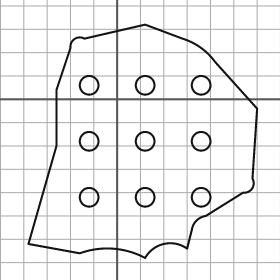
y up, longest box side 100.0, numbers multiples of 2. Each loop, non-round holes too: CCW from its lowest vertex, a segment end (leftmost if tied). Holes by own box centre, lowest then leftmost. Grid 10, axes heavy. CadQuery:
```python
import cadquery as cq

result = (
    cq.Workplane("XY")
    .moveTo(12.0, -68.0)
    .threePointArc((20.0, -62.0), (30.0, -64.0))
    .lineTo(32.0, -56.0)
    .threePointArc((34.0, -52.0), (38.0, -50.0))
    .lineTo(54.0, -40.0)
    .threePointArc((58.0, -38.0), (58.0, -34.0))
    .lineTo(60.0, -4.0)
    .lineTo(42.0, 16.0)
    .threePointArc((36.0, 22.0), (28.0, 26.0))
    .lineTo(12.0, 32.0)
    .lineTo(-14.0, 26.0)
    .threePointArc((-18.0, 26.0), (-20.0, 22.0))
    .lineTo(-26.0, 4.0)
    .lineTo(-26.0, -20.0)
    .lineTo(-38.0, -62.0)
    .lineTo(-16.0, -66.0)
    .threePointArc((-2.0, -64.0), (12.0, -68.0))
    .close()
    .moveTo(-12.0, -42.0)
    .circle(4.0)
    .moveTo(12.0, -42.0)
    .circle(4.0)
    .moveTo(36.0, -42.0)
    .circle(4.0)
    .moveTo(-12.0, -18.0)
    .circle(4.0)
    .moveTo(12.0, -18.0)
    .circle(4.0)
    .moveTo(36.0, -18.0)
    .circle(4.0)
    .moveTo(-12.0, 6.0)
    .circle(4.0)
    .moveTo(12.0, 6.0)
    .circle(4.0)
    .moveTo(36.0, 6.0)
    .circle(4.0)
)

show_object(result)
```